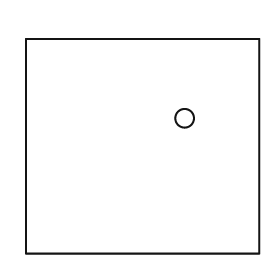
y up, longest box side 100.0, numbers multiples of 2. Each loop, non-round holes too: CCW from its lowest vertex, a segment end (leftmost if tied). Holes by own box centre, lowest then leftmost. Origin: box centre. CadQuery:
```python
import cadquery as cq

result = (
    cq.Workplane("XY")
    .moveTo(-50.0, -46.0)
    .lineTo(50.0, -46.0)
    .lineTo(50.0, 46.0)
    .lineTo(-50.0, 46.0)
    .close()
    .moveTo(18.0, 12.0)
    .circle(4.0)
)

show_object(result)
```